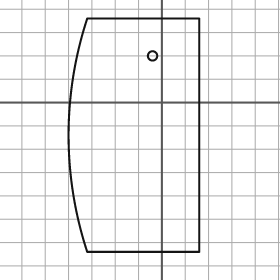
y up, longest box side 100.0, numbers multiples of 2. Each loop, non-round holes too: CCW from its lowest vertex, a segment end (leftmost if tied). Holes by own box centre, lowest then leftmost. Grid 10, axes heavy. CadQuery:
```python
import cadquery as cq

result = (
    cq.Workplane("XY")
    .moveTo(-32.0, -64.0)
    .lineTo(16.0, -64.0)
    .lineTo(16.0, 36.0)
    .lineTo(-32.0, 36.0)
    .threePointArc((-40.0, -14.0), (-32.0, -64.0))
    .close()
    .moveTo(-4.0, 20.0)
    .circle(2.0)
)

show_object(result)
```